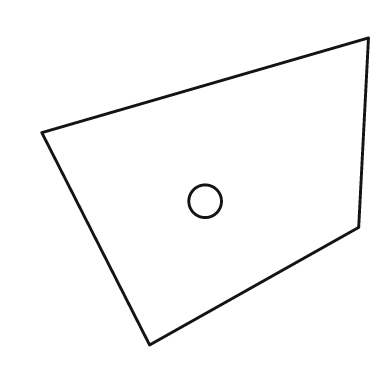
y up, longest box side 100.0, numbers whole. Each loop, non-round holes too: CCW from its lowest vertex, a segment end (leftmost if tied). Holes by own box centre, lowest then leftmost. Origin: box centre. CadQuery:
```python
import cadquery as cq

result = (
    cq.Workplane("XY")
    .moveTo(-17.0, -47.0)
    .lineTo(47.0, -11.0)
    .lineTo(50.0, 47.0)
    .lineTo(-50.0, 18.0)
    .close()
    .moveTo(0.0, -3.0)
    .circle(5.0)
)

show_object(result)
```